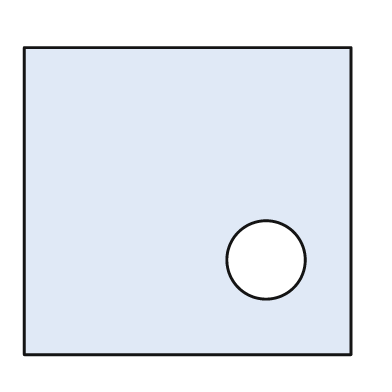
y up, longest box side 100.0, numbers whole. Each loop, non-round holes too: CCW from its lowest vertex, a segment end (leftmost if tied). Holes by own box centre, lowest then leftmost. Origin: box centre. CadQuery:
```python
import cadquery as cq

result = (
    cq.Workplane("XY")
    .moveTo(-50.0, -47.0)
    .lineTo(50.0, -47.0)
    .lineTo(50.0, 47.0)
    .lineTo(-50.0, 47.0)
    .close()
    .moveTo(24.0, -18.0)
    .circle(12.0)
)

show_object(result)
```